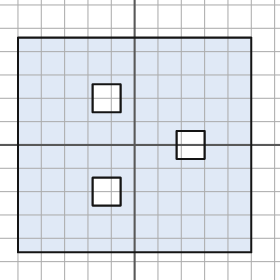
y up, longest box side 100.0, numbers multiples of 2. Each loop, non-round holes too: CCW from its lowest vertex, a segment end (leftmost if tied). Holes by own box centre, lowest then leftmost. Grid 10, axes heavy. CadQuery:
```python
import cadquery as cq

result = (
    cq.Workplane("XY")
    .moveTo(-50.0, -46.0)
    .lineTo(50.0, -46.0)
    .lineTo(50.0, 46.0)
    .lineTo(-50.0, 46.0)
    .close()
    .moveTo(-18.0, -26.0)
    .lineTo(-6.0, -26.0)
    .lineTo(-6.0, -14.0)
    .lineTo(-18.0, -14.0)
    .close()
    .moveTo(18.0, -6.0)
    .lineTo(30.0, -6.0)
    .lineTo(30.0, 6.0)
    .lineTo(18.0, 6.0)
    .close()
    .moveTo(-18.0, 14.0)
    .lineTo(-6.0, 14.0)
    .lineTo(-6.0, 26.0)
    .lineTo(-18.0, 26.0)
    .close()
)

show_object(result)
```